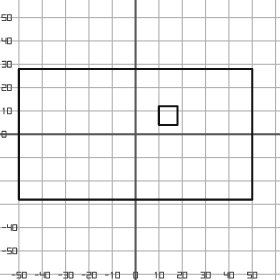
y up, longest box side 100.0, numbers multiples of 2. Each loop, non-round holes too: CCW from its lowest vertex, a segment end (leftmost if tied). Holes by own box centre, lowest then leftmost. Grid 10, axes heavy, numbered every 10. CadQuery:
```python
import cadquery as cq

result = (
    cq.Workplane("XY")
    .moveTo(-50.0, -28.0)
    .lineTo(50.0, -28.0)
    .lineTo(50.0, 28.0)
    .lineTo(-50.0, 28.0)
    .close()
    .moveTo(10.0, 4.0)
    .lineTo(18.0, 4.0)
    .lineTo(18.0, 12.0)
    .lineTo(10.0, 12.0)
    .close()
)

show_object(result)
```